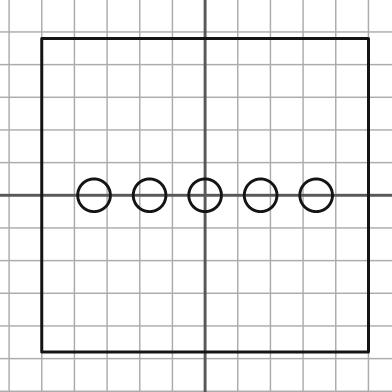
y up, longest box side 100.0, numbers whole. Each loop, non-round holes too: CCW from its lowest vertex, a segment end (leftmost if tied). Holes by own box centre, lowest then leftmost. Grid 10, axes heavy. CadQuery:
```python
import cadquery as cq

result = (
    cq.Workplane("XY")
    .moveTo(-50.0, -48.0)
    .lineTo(50.0, -48.0)
    .lineTo(50.0, 48.0)
    .lineTo(-50.0, 48.0)
    .close()
    .moveTo(-34.0, 0.0)
    .circle(5.0)
    .moveTo(-17.0, 0.0)
    .circle(5.0)
    .moveTo(0.0, 0.0)
    .circle(5.0)
    .moveTo(17.0, 0.0)
    .circle(5.0)
    .moveTo(34.0, 0.0)
    .circle(5.0)
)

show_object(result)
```